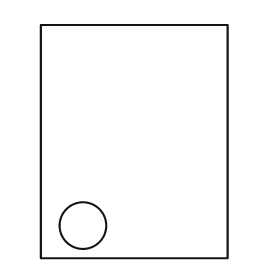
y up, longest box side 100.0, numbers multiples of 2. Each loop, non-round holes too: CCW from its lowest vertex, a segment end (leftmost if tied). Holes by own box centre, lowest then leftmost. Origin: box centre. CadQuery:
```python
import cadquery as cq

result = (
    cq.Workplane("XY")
    .moveTo(-40.0, -50.0)
    .lineTo(40.0, -50.0)
    .lineTo(40.0, 50.0)
    .lineTo(-40.0, 50.0)
    .close()
    .moveTo(-22.0, -36.0)
    .circle(10.0)
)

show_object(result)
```